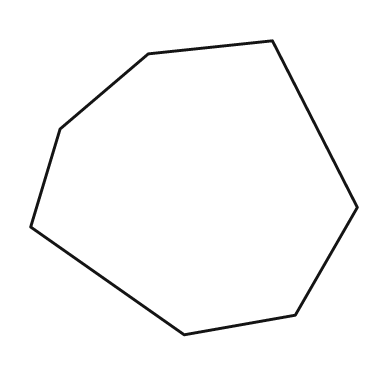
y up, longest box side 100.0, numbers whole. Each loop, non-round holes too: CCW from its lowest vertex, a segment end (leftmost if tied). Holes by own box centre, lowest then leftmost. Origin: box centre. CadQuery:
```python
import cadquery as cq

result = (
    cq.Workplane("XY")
    .moveTo(-3.0, -45.0)
    .lineTo(31.0, -39.0)
    .lineTo(50.0, -6.0)
    .lineTo(24.0, 45.0)
    .lineTo(-14.0, 41.0)
    .lineTo(-41.0, 18.0)
    .lineTo(-50.0, -12.0)
    .close()
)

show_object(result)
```